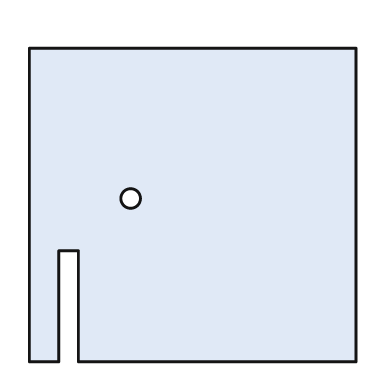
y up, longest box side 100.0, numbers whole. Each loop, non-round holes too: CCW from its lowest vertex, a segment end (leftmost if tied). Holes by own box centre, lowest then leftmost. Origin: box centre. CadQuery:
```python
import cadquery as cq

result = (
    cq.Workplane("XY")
    .moveTo(-50.0, -48.0)
    .lineTo(-41.0, -48.0)
    .lineTo(-41.0, -14.0)
    .lineTo(-35.0, -14.0)
    .lineTo(-35.0, -48.0)
    .lineTo(50.0, -48.0)
    .lineTo(50.0, 48.0)
    .lineTo(-50.0, 48.0)
    .close()
    .moveTo(-19.0, 2.0)
    .circle(3.0)
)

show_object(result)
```